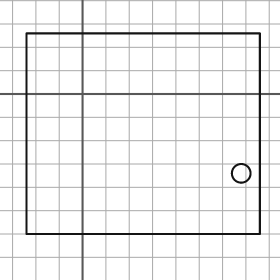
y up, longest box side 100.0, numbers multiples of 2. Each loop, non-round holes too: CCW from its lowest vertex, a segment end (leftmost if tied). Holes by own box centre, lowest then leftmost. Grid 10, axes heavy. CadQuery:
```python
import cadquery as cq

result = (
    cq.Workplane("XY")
    .moveTo(-24.0, -60.0)
    .lineTo(76.0, -60.0)
    .lineTo(76.0, 26.0)
    .lineTo(-24.0, 26.0)
    .close()
    .moveTo(68.0, -34.0)
    .circle(4.0)
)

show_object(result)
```